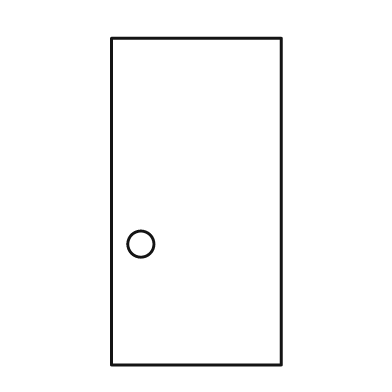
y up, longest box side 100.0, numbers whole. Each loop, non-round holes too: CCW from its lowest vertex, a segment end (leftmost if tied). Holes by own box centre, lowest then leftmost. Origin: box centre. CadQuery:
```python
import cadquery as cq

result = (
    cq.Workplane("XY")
    .moveTo(-26.0, -50.0)
    .lineTo(26.0, -50.0)
    .lineTo(26.0, 50.0)
    .lineTo(-26.0, 50.0)
    .close()
    .moveTo(-17.0, -13.0)
    .circle(4.0)
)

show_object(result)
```